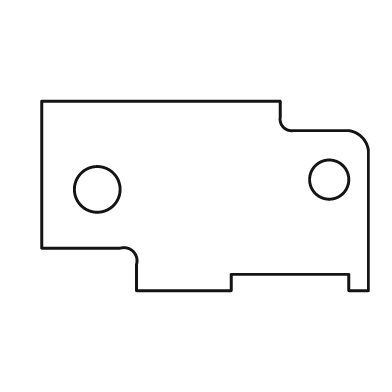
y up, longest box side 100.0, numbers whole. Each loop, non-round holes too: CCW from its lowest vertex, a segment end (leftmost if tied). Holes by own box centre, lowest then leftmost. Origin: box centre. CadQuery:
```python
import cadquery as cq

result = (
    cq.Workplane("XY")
    .moveTo(-21.0, -29.0)
    .lineTo(8.0, -29.0)
    .lineTo(8.0, -24.0)
    .lineTo(44.0, -24.0)
    .lineTo(44.0, -29.0)
    .lineTo(50.0, -29.0)
    .lineTo(50.0, 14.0)
    .threePointArc((48.0, 18.0), (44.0, 20.0))
    .lineTo(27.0, 20.0)
    .threePointArc((24.0, 21.0), (23.0, 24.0))
    .lineTo(23.0, 29.0)
    .lineTo(-50.0, 29.0)
    .lineTo(-50.0, -16.0)
    .lineTo(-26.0, -16.0)
    .threePointArc((-22.0, -17.0), (-21.0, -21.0))
    .close()
    .moveTo(-33.0, 2.0)
    .circle(7.0)
    .moveTo(38.0, 5.0)
    .circle(6.0)
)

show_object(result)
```